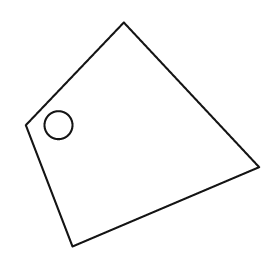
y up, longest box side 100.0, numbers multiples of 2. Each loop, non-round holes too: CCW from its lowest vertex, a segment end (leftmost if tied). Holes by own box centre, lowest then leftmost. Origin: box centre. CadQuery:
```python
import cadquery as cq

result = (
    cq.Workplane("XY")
    .moveTo(-30.0, -48.0)
    .lineTo(50.0, -14.0)
    .lineTo(-8.0, 48.0)
    .lineTo(-50.0, 4.0)
    .close()
    .moveTo(-36.0, 4.0)
    .circle(6.0)
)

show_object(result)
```